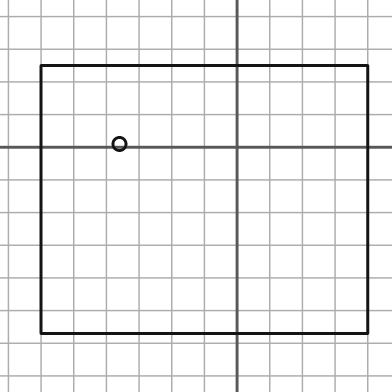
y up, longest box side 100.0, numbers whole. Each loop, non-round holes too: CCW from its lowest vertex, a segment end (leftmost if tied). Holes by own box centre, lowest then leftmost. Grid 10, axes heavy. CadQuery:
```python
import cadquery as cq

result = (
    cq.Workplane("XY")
    .moveTo(-60.0, -57.0)
    .lineTo(40.0, -57.0)
    .lineTo(40.0, 25.0)
    .lineTo(-60.0, 25.0)
    .close()
    .moveTo(-36.0, 1.0)
    .circle(2.0)
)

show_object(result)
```